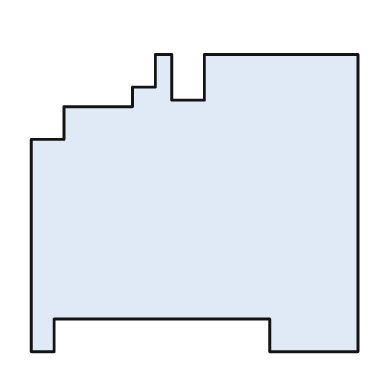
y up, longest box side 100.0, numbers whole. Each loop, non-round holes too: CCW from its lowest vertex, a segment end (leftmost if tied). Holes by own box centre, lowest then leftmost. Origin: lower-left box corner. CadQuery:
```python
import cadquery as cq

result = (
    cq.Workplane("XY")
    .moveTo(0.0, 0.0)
    .lineTo(7.0, 0.0)
    .lineTo(7.0, 10.0)
    .lineTo(73.0, 10.0)
    .lineTo(73.0, 0.0)
    .lineTo(100.0, 0.0)
    .lineTo(100.0, 91.0)
    .lineTo(53.0, 91.0)
    .lineTo(53.0, 77.0)
    .lineTo(43.0, 77.0)
    .lineTo(43.0, 91.0)
    .lineTo(38.0, 91.0)
    .lineTo(38.0, 81.0)
    .lineTo(31.0, 81.0)
    .lineTo(31.0, 75.0)
    .lineTo(10.0, 75.0)
    .lineTo(10.0, 65.0)
    .lineTo(0.0, 65.0)
    .close()
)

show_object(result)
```